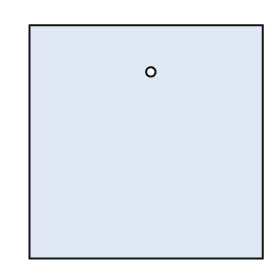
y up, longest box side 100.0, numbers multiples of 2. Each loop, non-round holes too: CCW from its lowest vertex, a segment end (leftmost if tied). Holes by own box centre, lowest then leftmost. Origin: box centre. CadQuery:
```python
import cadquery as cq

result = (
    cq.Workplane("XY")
    .moveTo(-50.0, -50.0)
    .lineTo(50.0, -50.0)
    .lineTo(50.0, 50.0)
    .lineTo(-50.0, 50.0)
    .close()
    .moveTo(2.0, 30.0)
    .circle(2.0)
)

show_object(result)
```